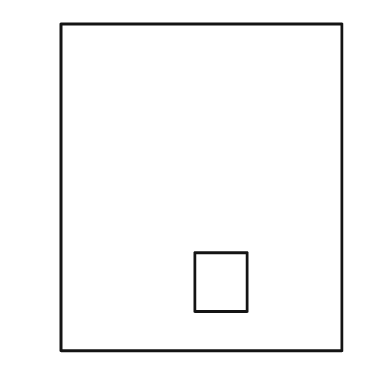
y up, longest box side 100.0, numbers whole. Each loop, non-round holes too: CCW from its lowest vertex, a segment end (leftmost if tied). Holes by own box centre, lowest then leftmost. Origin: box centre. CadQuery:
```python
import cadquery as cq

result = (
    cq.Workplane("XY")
    .moveTo(-43.0, -50.0)
    .lineTo(43.0, -50.0)
    .lineTo(43.0, 50.0)
    .lineTo(-43.0, 50.0)
    .close()
    .moveTo(-2.0, -38.0)
    .lineTo(14.0, -38.0)
    .lineTo(14.0, -20.0)
    .lineTo(-2.0, -20.0)
    .close()
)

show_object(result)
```